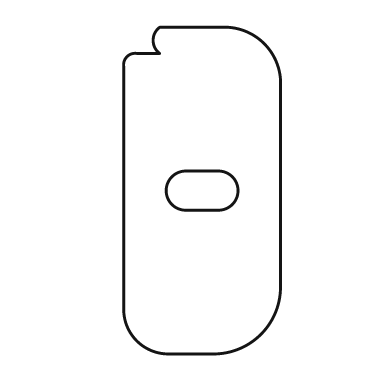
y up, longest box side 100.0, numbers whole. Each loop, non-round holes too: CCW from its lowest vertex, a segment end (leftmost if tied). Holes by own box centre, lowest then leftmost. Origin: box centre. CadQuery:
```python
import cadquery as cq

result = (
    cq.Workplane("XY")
    .moveTo(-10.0, -50.0)
    .lineTo(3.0, -50.0)
    .threePointArc((18.0, -44.0), (24.0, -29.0))
    .lineTo(24.0, 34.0)
    .threePointArc((19.0, 45.0), (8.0, 50.0))
    .lineTo(-13.0, 50.0)
    .threePointArc((-15.0, 46.0), (-13.0, 42.0))
    .lineTo(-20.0, 42.0)
    .threePointArc((-23.0, 41.0), (-24.0, 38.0))
    .lineTo(-24.0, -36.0)
    .threePointArc((-20.0, -46.0), (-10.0, -50.0))
    .close()
    .moveTo(-5.0, -6.0)
    .lineTo(5.0, -6.0)
    .threePointArc((11.0, 0.0), (5.0, 6.0))
    .lineTo(-5.0, 6.0)
    .threePointArc((-11.0, 0.0), (-5.0, -6.0))
    .close()
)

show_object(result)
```